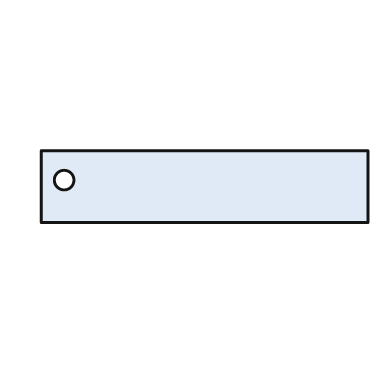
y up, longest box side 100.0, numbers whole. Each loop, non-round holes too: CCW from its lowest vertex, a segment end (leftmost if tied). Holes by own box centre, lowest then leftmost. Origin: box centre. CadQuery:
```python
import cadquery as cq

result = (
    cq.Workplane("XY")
    .moveTo(-50.0, -11.0)
    .lineTo(50.0, -11.0)
    .lineTo(50.0, 11.0)
    .lineTo(-50.0, 11.0)
    .close()
    .moveTo(-43.0, 2.0)
    .circle(3.0)
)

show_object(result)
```